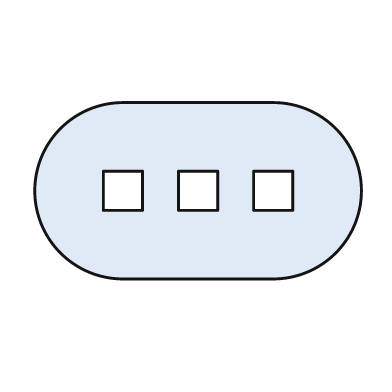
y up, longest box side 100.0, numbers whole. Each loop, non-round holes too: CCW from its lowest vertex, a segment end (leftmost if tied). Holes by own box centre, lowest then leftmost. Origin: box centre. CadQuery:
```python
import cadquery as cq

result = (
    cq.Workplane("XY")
    .moveTo(-23.0, -27.0)
    .lineTo(23.0, -27.0)
    .threePointArc((50.0, 0.0), (23.0, 27.0))
    .lineTo(-23.0, 27.0)
    .threePointArc((-50.0, 0.0), (-23.0, -27.0))
    .close()
    .moveTo(-29.0, -6.0)
    .lineTo(-17.0, -6.0)
    .lineTo(-17.0, 6.0)
    .lineTo(-29.0, 6.0)
    .close()
    .moveTo(-6.0, -6.0)
    .lineTo(6.0, -6.0)
    .lineTo(6.0, 6.0)
    .lineTo(-6.0, 6.0)
    .close()
    .moveTo(17.0, -6.0)
    .lineTo(29.0, -6.0)
    .lineTo(29.0, 6.0)
    .lineTo(17.0, 6.0)
    .close()
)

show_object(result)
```